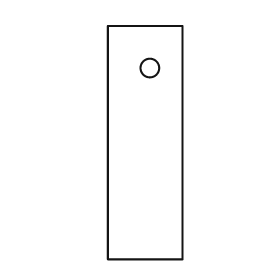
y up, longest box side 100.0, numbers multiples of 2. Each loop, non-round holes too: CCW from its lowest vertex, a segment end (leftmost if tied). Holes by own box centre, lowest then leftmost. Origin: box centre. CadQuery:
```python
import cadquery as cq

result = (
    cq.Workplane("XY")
    .moveTo(-16.0, -50.0)
    .lineTo(16.0, -50.0)
    .lineTo(16.0, 50.0)
    .lineTo(-16.0, 50.0)
    .close()
    .moveTo(2.0, 32.0)
    .circle(4.0)
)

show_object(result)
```